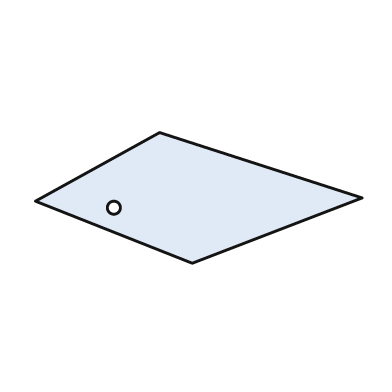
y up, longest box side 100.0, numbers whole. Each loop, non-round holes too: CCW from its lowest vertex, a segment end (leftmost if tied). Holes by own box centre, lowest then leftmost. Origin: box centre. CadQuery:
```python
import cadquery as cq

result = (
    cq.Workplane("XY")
    .moveTo(-2.0, -20.0)
    .lineTo(50.0, 0.0)
    .lineTo(-12.0, 20.0)
    .lineTo(-50.0, -1.0)
    .close()
    .moveTo(-26.0, -3.0)
    .circle(2.0)
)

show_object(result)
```